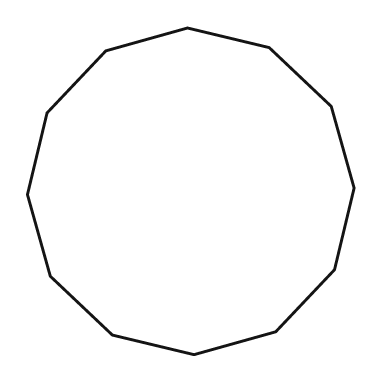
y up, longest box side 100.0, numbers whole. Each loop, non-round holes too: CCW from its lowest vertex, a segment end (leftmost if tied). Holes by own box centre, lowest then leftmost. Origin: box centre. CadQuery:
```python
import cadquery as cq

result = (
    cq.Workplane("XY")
    .moveTo(1.0, -50.0)
    .lineTo(26.0, -43.0)
    .lineTo(44.0, -24.0)
    .lineTo(50.0, 1.0)
    .lineTo(43.0, 26.0)
    .lineTo(24.0, 44.0)
    .lineTo(-1.0, 50.0)
    .lineTo(-26.0, 43.0)
    .lineTo(-44.0, 24.0)
    .lineTo(-50.0, -1.0)
    .lineTo(-43.0, -26.0)
    .lineTo(-24.0, -44.0)
    .close()
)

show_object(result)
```